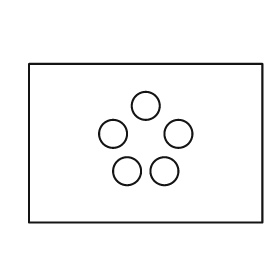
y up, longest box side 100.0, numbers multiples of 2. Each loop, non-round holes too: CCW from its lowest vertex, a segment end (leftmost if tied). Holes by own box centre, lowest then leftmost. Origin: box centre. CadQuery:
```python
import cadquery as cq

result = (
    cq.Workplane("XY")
    .moveTo(-50.0, -34.0)
    .lineTo(50.0, -34.0)
    .lineTo(50.0, 34.0)
    .lineTo(-50.0, 34.0)
    .close()
    .moveTo(-8.0, -12.0)
    .circle(6.0)
    .moveTo(8.0, -12.0)
    .circle(6.0)
    .moveTo(-14.0, 4.0)
    .circle(6.0)
    .moveTo(14.0, 4.0)
    .circle(6.0)
    .moveTo(0.0, 16.0)
    .circle(6.0)
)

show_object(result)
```